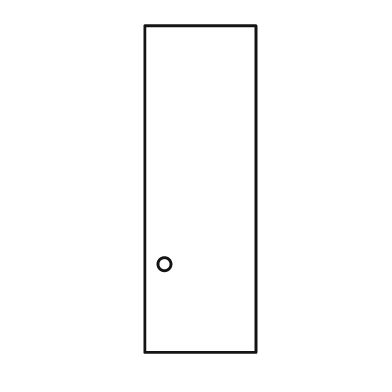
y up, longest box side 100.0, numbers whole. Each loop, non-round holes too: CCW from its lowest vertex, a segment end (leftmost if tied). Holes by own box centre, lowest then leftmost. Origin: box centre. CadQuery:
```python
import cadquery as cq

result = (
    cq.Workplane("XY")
    .moveTo(-17.0, -50.0)
    .lineTo(17.0, -50.0)
    .lineTo(17.0, 50.0)
    .lineTo(-17.0, 50.0)
    .close()
    .moveTo(-11.0, -23.0)
    .circle(2.0)
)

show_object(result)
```